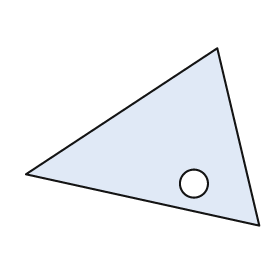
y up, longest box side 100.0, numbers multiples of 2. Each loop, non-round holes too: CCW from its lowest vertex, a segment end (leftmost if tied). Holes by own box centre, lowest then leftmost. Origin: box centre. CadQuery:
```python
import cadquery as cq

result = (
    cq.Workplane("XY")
    .moveTo(50.0, -38.0)
    .lineTo(32.0, 38.0)
    .lineTo(-50.0, -16.0)
    .close()
    .moveTo(22.0, -20.0)
    .circle(6.0)
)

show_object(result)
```